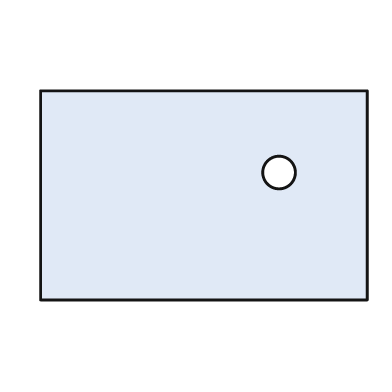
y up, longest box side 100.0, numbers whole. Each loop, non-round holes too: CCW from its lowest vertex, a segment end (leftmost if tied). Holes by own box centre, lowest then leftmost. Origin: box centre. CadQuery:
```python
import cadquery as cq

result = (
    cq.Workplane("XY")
    .moveTo(-50.0, -32.0)
    .lineTo(50.0, -32.0)
    .lineTo(50.0, 32.0)
    .lineTo(-50.0, 32.0)
    .close()
    .moveTo(23.0, 7.0)
    .circle(5.0)
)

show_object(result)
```